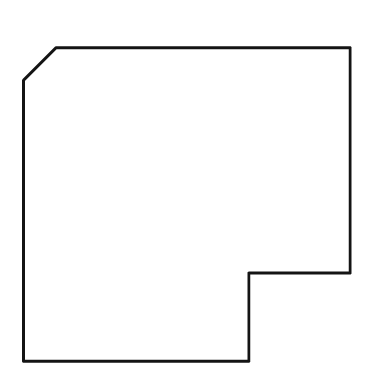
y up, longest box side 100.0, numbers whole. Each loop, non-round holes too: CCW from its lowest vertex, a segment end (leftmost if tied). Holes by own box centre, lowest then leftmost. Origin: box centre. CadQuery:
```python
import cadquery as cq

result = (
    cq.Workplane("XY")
    .moveTo(-50.0, -48.0)
    .lineTo(19.0, -48.0)
    .lineTo(19.0, -21.0)
    .lineTo(50.0, -21.0)
    .lineTo(50.0, 48.0)
    .lineTo(-40.0, 48.0)
    .lineTo(-50.0, 38.0)
    .close()
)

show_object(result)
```